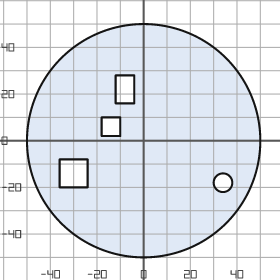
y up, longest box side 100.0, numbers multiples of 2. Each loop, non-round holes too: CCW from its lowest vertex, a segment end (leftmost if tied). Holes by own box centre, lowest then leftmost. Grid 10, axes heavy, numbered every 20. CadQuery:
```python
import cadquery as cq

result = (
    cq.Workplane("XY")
    .moveTo(0.0, 0.0)
    .circle(50.0)
    .moveTo(34.0, -18.0)
    .circle(4.0)
    .moveTo(-36.0, -20.0)
    .lineTo(-24.0, -20.0)
    .lineTo(-24.0, -8.0)
    .lineTo(-36.0, -8.0)
    .close()
    .moveTo(-18.0, 2.0)
    .lineTo(-10.0, 2.0)
    .lineTo(-10.0, 10.0)
    .lineTo(-18.0, 10.0)
    .close()
    .moveTo(-12.0, 16.0)
    .lineTo(-4.0, 16.0)
    .lineTo(-4.0, 28.0)
    .lineTo(-12.0, 28.0)
    .close()
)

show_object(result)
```